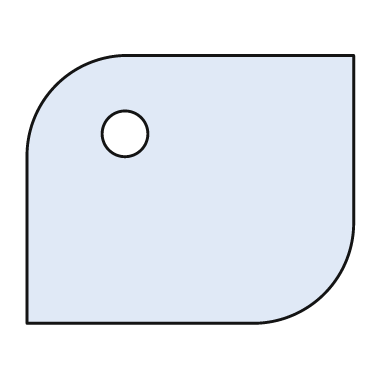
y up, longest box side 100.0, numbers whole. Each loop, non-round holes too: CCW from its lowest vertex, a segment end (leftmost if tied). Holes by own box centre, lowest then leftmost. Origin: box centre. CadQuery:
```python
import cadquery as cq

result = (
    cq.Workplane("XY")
    .moveTo(-50.0, -41.0)
    .lineTo(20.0, -41.0)
    .threePointArc((41.0, -32.0), (50.0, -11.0))
    .lineTo(50.0, 41.0)
    .lineTo(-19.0, 41.0)
    .threePointArc((-41.0, 32.0), (-50.0, 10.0))
    .close()
    .moveTo(-20.0, 17.0)
    .circle(7.0)
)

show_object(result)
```